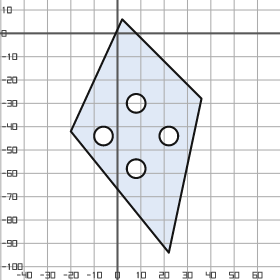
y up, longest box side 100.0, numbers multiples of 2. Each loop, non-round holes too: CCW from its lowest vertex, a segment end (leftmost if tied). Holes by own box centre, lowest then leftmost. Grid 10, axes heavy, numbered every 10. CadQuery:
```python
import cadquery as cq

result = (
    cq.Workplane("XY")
    .moveTo(22.0, -94.0)
    .lineTo(36.0, -28.0)
    .lineTo(2.0, 6.0)
    .lineTo(-20.0, -42.0)
    .close()
    .moveTo(8.0, -58.0)
    .circle(4.0)
    .moveTo(-6.0, -44.0)
    .circle(4.0)
    .moveTo(22.0, -44.0)
    .circle(4.0)
    .moveTo(8.0, -30.0)
    .circle(4.0)
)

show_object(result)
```